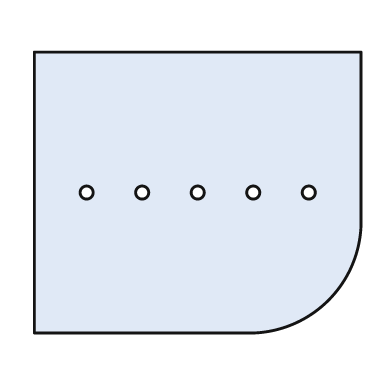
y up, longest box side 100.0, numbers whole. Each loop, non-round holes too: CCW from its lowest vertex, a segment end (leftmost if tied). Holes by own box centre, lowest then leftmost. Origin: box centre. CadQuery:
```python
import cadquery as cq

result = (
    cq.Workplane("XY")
    .moveTo(-50.0, -43.0)
    .lineTo(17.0, -43.0)
    .threePointArc((40.0, -33.0), (50.0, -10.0))
    .lineTo(50.0, 43.0)
    .lineTo(-50.0, 43.0)
    .close()
    .moveTo(-34.0, 0.0)
    .circle(2.0)
    .moveTo(-17.0, 0.0)
    .circle(2.0)
    .moveTo(0.0, 0.0)
    .circle(2.0)
    .moveTo(17.0, 0.0)
    .circle(2.0)
    .moveTo(34.0, 0.0)
    .circle(2.0)
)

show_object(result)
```